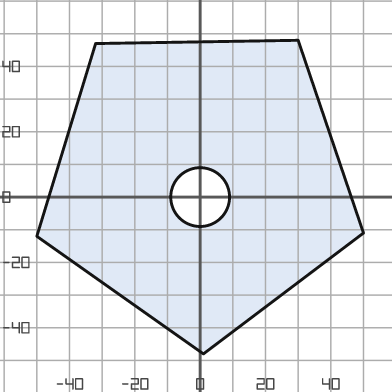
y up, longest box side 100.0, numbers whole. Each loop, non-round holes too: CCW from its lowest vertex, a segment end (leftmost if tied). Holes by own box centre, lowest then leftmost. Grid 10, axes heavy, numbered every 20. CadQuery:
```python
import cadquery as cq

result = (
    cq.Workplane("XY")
    .moveTo(1.0, -48.0)
    .lineTo(50.0, -11.0)
    .lineTo(30.0, 48.0)
    .lineTo(-32.0, 47.0)
    .lineTo(-50.0, -12.0)
    .close()
    .moveTo(0.0, 0.0)
    .circle(9.0)
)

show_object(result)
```